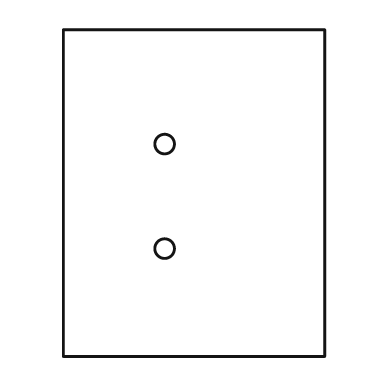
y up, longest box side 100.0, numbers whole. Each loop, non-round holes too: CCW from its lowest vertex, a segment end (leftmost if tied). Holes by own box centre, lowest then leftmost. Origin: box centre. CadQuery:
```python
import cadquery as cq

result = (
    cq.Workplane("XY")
    .moveTo(-40.0, -50.0)
    .lineTo(40.0, -50.0)
    .lineTo(40.0, 50.0)
    .lineTo(-40.0, 50.0)
    .close()
    .moveTo(-9.0, -17.0)
    .circle(3.0)
    .moveTo(-9.0, 15.0)
    .circle(3.0)
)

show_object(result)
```